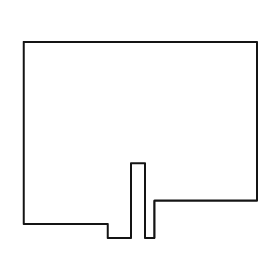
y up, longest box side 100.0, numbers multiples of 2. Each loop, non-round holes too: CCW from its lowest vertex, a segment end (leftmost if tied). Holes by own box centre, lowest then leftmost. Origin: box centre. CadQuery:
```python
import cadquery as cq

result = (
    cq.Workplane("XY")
    .moveTo(-14.0, -42.0)
    .lineTo(-4.0, -42.0)
    .lineTo(-4.0, -10.0)
    .lineTo(2.0, -10.0)
    .lineTo(2.0, -42.0)
    .lineTo(6.0, -42.0)
    .lineTo(6.0, -26.0)
    .lineTo(50.0, -26.0)
    .lineTo(50.0, 42.0)
    .lineTo(-50.0, 42.0)
    .lineTo(-50.0, -36.0)
    .lineTo(-14.0, -36.0)
    .close()
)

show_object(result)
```